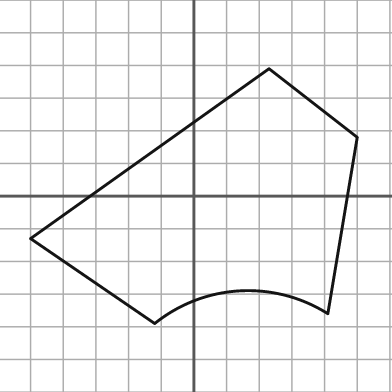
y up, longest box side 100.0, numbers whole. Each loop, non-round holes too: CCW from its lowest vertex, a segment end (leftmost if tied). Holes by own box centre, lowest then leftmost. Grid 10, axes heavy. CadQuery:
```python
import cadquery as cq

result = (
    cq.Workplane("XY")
    .moveTo(-12.0, -39.0)
    .threePointArc((14.0, -29.0), (41.0, -36.0))
    .lineTo(50.0, 18.0)
    .lineTo(23.0, 39.0)
    .lineTo(-50.0, -13.0)
    .close()
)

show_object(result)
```